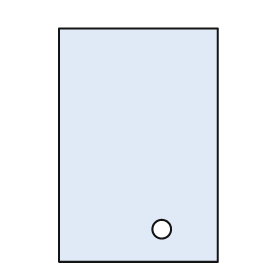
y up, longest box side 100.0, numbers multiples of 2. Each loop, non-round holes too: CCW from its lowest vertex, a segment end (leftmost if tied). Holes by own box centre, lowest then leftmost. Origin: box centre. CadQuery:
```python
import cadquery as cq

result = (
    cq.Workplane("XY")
    .moveTo(-34.0, -50.0)
    .lineTo(34.0, -50.0)
    .lineTo(34.0, 50.0)
    .lineTo(-34.0, 50.0)
    .close()
    .moveTo(10.0, -36.0)
    .circle(4.0)
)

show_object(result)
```